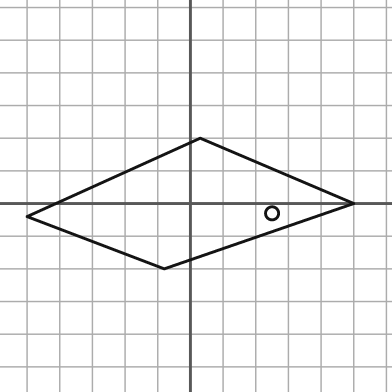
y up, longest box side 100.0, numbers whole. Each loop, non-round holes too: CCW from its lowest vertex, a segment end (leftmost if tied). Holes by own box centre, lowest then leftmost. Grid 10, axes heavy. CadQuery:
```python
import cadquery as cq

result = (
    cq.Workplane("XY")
    .moveTo(-8.0, -20.0)
    .lineTo(50.0, 0.0)
    .lineTo(3.0, 20.0)
    .lineTo(-50.0, -4.0)
    .close()
    .moveTo(25.0, -3.0)
    .circle(2.0)
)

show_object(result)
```